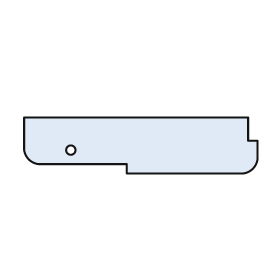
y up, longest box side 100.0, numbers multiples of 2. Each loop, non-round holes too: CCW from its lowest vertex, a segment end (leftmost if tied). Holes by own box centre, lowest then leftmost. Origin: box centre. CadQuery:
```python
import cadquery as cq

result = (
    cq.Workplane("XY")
    .moveTo(-6.0, -12.0)
    .lineTo(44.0, -12.0)
    .threePointArc((48.0, -10.0), (50.0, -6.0))
    .lineTo(50.0, 2.0)
    .lineTo(46.0, 2.0)
    .lineTo(46.0, 12.0)
    .lineTo(-50.0, 12.0)
    .lineTo(-50.0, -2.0)
    .threePointArc((-48.0, -6.0), (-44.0, -8.0))
    .lineTo(-6.0, -8.0)
    .close()
    .moveTo(-30.0, -2.0)
    .circle(2.0)
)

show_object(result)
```